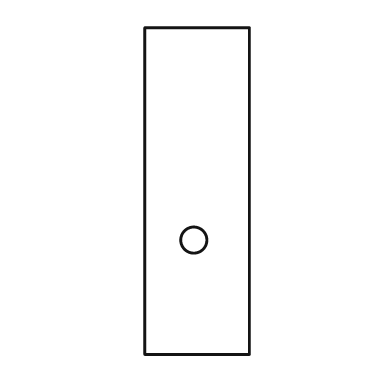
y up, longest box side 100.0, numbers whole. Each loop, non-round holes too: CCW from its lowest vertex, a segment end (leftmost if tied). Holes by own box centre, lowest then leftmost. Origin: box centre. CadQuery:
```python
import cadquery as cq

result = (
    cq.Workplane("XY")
    .moveTo(-16.0, -50.0)
    .lineTo(16.0, -50.0)
    .lineTo(16.0, 50.0)
    .lineTo(-16.0, 50.0)
    .close()
    .moveTo(-1.0, -15.0)
    .circle(4.0)
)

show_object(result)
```